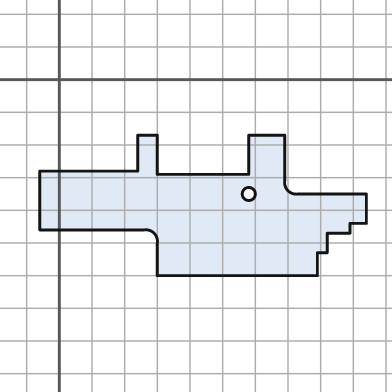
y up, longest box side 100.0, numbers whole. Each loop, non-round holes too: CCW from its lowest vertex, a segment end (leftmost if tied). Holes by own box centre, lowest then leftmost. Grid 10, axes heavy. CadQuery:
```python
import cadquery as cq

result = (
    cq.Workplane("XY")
    .moveTo(30.0, -60.0)
    .lineTo(79.0, -60.0)
    .lineTo(79.0, -53.0)
    .lineTo(82.0, -53.0)
    .lineTo(82.0, -47.0)
    .lineTo(89.0, -47.0)
    .lineTo(89.0, -44.0)
    .lineTo(94.0, -44.0)
    .lineTo(94.0, -35.0)
    .lineTo(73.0, -35.0)
    .threePointArc((70.0, -34.0), (69.0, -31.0))
    .lineTo(69.0, -17.0)
    .lineTo(58.0, -17.0)
    .lineTo(58.0, -29.0)
    .lineTo(30.0, -29.0)
    .lineTo(30.0, -17.0)
    .lineTo(24.0, -17.0)
    .lineTo(24.0, -28.0)
    .lineTo(-6.0, -28.0)
    .lineTo(-6.0, -46.0)
    .lineTo(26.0, -46.0)
    .threePointArc((29.0, -47.0), (30.0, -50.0))
    .close()
    .moveTo(58.0, -35.0)
    .circle(2.0)
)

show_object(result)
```